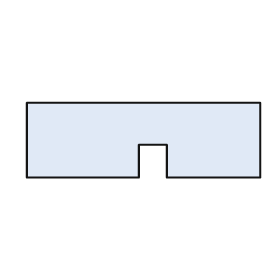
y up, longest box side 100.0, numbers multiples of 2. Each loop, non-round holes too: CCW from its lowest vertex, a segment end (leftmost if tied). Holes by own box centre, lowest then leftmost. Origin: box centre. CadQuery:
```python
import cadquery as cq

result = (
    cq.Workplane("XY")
    .moveTo(-50.0, -16.0)
    .lineTo(-2.0, -16.0)
    .lineTo(-2.0, -2.0)
    .lineTo(10.0, -2.0)
    .lineTo(10.0, -16.0)
    .lineTo(50.0, -16.0)
    .lineTo(50.0, 16.0)
    .lineTo(-50.0, 16.0)
    .close()
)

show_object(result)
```